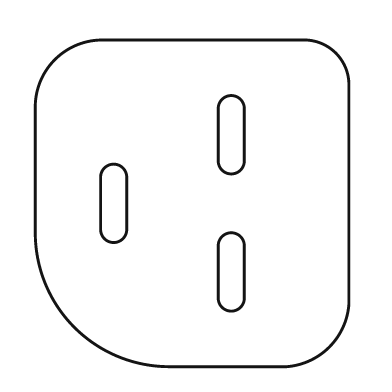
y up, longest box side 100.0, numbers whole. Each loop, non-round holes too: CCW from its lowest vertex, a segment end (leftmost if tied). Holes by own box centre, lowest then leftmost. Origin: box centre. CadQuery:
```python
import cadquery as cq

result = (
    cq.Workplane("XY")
    .moveTo(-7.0, -50.0)
    .lineTo(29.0, -50.0)
    .threePointArc((42.0, -44.0), (48.0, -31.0))
    .lineTo(48.0, 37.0)
    .threePointArc((44.0, 46.0), (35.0, 50.0))
    .lineTo(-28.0, 50.0)
    .threePointArc((-42.0, 44.0), (-48.0, 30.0))
    .lineTo(-48.0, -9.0)
    .threePointArc((-36.0, -38.0), (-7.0, -50.0))
    .close()
    .moveTo(8.0, -29.0)
    .threePointArc((12.0, -33.0), (16.0, -29.0))
    .lineTo(16.0, -13.0)
    .threePointArc((12.0, -9.0), (8.0, -13.0))
    .close()
    .moveTo(-28.0, -8.0)
    .threePointArc((-24.0, -12.0), (-20.0, -8.0))
    .lineTo(-20.0, 8.0)
    .threePointArc((-24.0, 12.0), (-28.0, 8.0))
    .close()
    .moveTo(8.0, 13.0)
    .threePointArc((12.0, 9.0), (16.0, 13.0))
    .lineTo(16.0, 29.0)
    .threePointArc((12.0, 33.0), (8.0, 29.0))
    .close()
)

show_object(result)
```